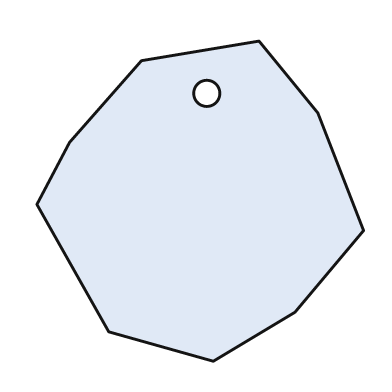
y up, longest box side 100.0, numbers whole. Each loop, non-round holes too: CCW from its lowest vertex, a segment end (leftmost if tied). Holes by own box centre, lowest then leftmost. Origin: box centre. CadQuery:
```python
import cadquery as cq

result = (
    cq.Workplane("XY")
    .moveTo(4.0, -49.0)
    .lineTo(29.0, -34.0)
    .lineTo(50.0, -9.0)
    .lineTo(36.0, 27.0)
    .lineTo(18.0, 49.0)
    .lineTo(-18.0, 43.0)
    .lineTo(-40.0, 18.0)
    .lineTo(-50.0, -1.0)
    .lineTo(-28.0, -40.0)
    .close()
    .moveTo(2.0, 33.0)
    .circle(4.0)
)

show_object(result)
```